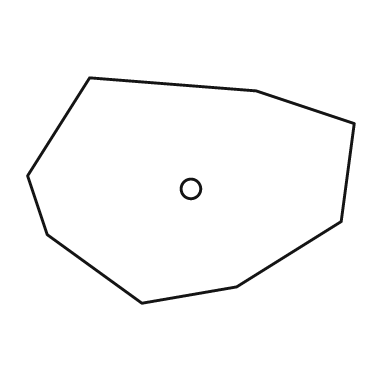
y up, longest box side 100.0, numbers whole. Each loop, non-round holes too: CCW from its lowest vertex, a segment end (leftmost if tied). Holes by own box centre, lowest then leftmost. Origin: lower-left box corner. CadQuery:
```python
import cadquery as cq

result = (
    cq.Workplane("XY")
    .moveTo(35.0, 0.0)
    .lineTo(64.0, 5.0)
    .lineTo(96.0, 25.0)
    .lineTo(100.0, 55.0)
    .lineTo(70.0, 65.0)
    .lineTo(19.0, 69.0)
    .lineTo(0.0, 39.0)
    .lineTo(6.0, 21.0)
    .close()
    .moveTo(50.0, 35.0)
    .circle(3.0)
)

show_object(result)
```